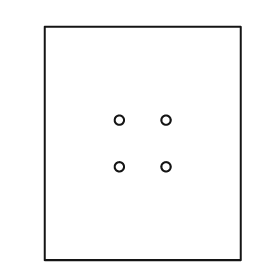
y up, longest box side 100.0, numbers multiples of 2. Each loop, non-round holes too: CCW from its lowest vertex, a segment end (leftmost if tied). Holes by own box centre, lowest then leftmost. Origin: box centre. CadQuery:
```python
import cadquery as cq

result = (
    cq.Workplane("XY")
    .moveTo(-42.0, -50.0)
    .lineTo(42.0, -50.0)
    .lineTo(42.0, 50.0)
    .lineTo(-42.0, 50.0)
    .close()
    .moveTo(-10.0, -10.0)
    .circle(2.0)
    .moveTo(10.0, -10.0)
    .circle(2.0)
    .moveTo(-10.0, 10.0)
    .circle(2.0)
    .moveTo(10.0, 10.0)
    .circle(2.0)
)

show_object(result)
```